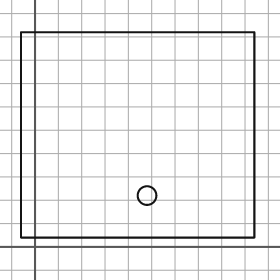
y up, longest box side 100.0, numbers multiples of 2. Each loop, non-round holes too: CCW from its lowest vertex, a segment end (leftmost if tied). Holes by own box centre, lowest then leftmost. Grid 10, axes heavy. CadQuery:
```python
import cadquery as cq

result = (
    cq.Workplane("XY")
    .moveTo(-6.0, 4.0)
    .lineTo(94.0, 4.0)
    .lineTo(94.0, 92.0)
    .lineTo(-6.0, 92.0)
    .close()
    .moveTo(48.0, 22.0)
    .circle(4.0)
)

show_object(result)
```